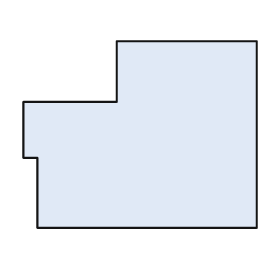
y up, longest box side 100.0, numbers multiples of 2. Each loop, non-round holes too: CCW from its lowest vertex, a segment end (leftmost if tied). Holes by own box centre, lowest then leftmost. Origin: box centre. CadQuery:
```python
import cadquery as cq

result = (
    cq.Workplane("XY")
    .moveTo(-44.0, -40.0)
    .lineTo(50.0, -40.0)
    .lineTo(50.0, 40.0)
    .lineTo(-10.0, 40.0)
    .lineTo(-10.0, 14.0)
    .lineTo(-50.0, 14.0)
    .lineTo(-50.0, -10.0)
    .lineTo(-44.0, -10.0)
    .close()
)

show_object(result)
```